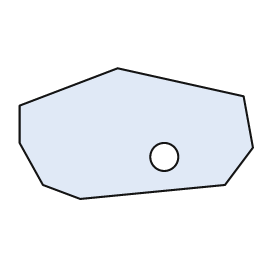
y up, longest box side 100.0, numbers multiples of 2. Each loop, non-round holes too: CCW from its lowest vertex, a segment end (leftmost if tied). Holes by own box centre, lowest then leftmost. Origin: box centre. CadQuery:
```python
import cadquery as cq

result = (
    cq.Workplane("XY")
    .moveTo(-24.0, -28.0)
    .lineTo(38.0, -22.0)
    .lineTo(50.0, -6.0)
    .lineTo(46.0, 16.0)
    .lineTo(-8.0, 28.0)
    .lineTo(-50.0, 12.0)
    .lineTo(-50.0, -4.0)
    .lineTo(-40.0, -22.0)
    .close()
    .moveTo(12.0, -10.0)
    .circle(6.0)
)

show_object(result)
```